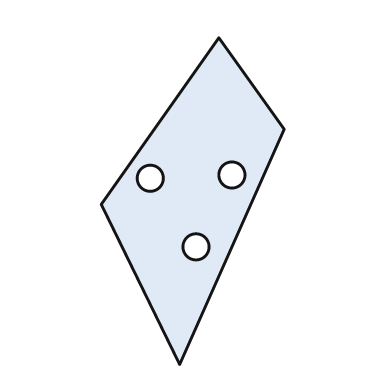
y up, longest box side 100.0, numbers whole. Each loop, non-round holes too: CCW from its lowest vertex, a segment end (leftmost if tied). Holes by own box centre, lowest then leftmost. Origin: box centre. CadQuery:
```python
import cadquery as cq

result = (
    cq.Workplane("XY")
    .moveTo(-4.0, -50.0)
    .lineTo(28.0, 22.0)
    .lineTo(8.0, 50.0)
    .lineTo(-28.0, -1.0)
    .close()
    .moveTo(1.0, -14.0)
    .circle(4.0)
    .moveTo(-13.0, 7.0)
    .circle(4.0)
    .moveTo(12.0, 8.0)
    .circle(4.0)
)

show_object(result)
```